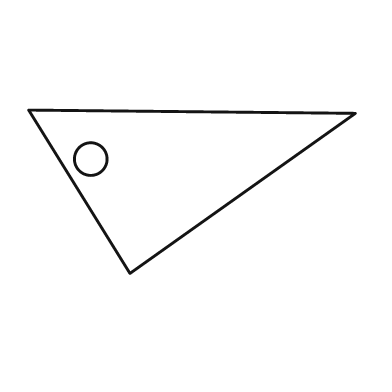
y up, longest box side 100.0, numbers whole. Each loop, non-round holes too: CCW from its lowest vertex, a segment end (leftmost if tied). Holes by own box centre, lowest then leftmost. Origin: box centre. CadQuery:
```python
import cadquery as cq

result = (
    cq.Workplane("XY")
    .moveTo(-19.0, -25.0)
    .lineTo(50.0, 24.0)
    .lineTo(-50.0, 25.0)
    .close()
    .moveTo(-31.0, 10.0)
    .circle(5.0)
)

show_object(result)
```